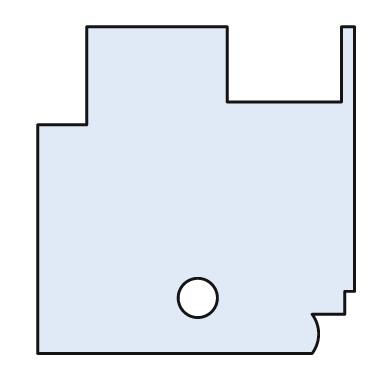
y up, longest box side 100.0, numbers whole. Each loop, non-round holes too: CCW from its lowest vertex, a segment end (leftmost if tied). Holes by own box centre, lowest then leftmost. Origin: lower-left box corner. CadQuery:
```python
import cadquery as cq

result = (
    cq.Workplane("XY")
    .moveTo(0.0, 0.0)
    .lineTo(84.0, 0.0)
    .threePointArc((86.0, 6.0), (84.0, 12.0))
    .lineTo(94.0, 12.0)
    .lineTo(94.0, 19.0)
    .lineTo(97.0, 19.0)
    .lineTo(97.0, 100.0)
    .lineTo(93.0, 100.0)
    .lineTo(93.0, 77.0)
    .lineTo(58.0, 77.0)
    .lineTo(58.0, 100.0)
    .lineTo(15.0, 100.0)
    .lineTo(15.0, 70.0)
    .lineTo(0.0, 70.0)
    .close()
    .moveTo(49.0, 17.0)
    .circle(6.0)
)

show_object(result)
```